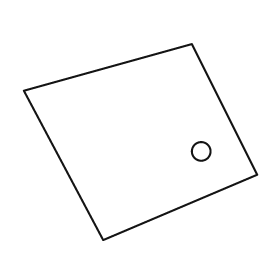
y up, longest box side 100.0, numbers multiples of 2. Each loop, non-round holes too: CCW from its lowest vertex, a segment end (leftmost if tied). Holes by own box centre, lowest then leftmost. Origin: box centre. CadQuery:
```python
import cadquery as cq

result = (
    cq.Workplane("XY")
    .moveTo(-16.0, -42.0)
    .lineTo(50.0, -14.0)
    .lineTo(22.0, 42.0)
    .lineTo(-50.0, 22.0)
    .close()
    .moveTo(26.0, -4.0)
    .circle(4.0)
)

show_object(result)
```